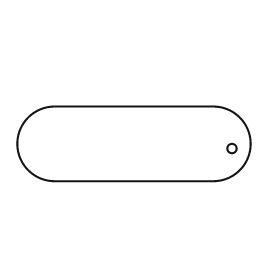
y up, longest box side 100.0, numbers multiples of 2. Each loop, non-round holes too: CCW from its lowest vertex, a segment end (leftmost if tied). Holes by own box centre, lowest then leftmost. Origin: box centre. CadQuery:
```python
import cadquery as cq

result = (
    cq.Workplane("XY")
    .moveTo(-34.0, -16.0)
    .lineTo(34.0, -16.0)
    .threePointArc((50.0, 0.0), (34.0, 16.0))
    .lineTo(-34.0, 16.0)
    .threePointArc((-50.0, 0.0), (-34.0, -16.0))
    .close()
    .moveTo(42.0, -2.0)
    .circle(2.0)
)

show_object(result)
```